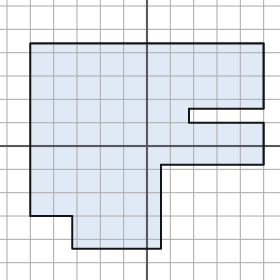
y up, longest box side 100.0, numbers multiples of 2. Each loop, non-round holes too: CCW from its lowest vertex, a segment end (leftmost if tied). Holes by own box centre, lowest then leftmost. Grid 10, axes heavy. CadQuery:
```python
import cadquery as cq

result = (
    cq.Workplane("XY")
    .moveTo(-32.0, -44.0)
    .lineTo(6.0, -44.0)
    .lineTo(6.0, -8.0)
    .lineTo(50.0, -8.0)
    .lineTo(50.0, 10.0)
    .lineTo(18.0, 10.0)
    .lineTo(18.0, 16.0)
    .lineTo(50.0, 16.0)
    .lineTo(50.0, 44.0)
    .lineTo(-50.0, 44.0)
    .lineTo(-50.0, -30.0)
    .lineTo(-32.0, -30.0)
    .close()
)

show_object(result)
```